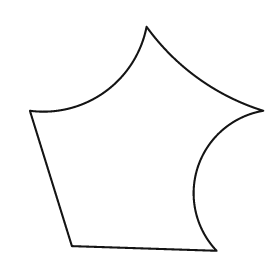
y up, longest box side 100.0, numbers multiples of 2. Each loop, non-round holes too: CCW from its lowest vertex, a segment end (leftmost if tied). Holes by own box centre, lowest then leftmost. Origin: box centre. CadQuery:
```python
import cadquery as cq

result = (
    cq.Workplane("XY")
    .moveTo(30.0, -48.0)
    .threePointArc((22.0, -12.0), (50.0, 12.0))
    .threePointArc((22.0, 26.0), (0.0, 48.0))
    .threePointArc((-18.0, 20.0), (-50.0, 12.0))
    .lineTo(-32.0, -46.0)
    .close()
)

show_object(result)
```